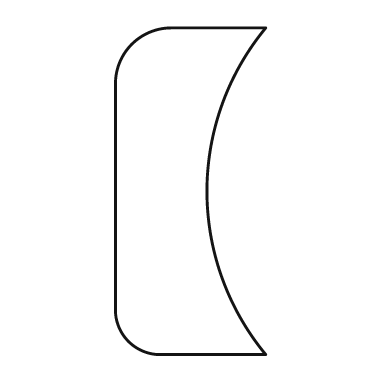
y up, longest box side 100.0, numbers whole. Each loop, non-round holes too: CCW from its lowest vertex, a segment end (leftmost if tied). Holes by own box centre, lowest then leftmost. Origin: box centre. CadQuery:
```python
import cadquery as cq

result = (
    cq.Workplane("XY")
    .moveTo(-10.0, -50.0)
    .lineTo(23.0, -50.0)
    .threePointArc((5.0, 0.0), (23.0, 50.0))
    .lineTo(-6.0, 50.0)
    .threePointArc((-18.0, 45.0), (-23.0, 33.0))
    .lineTo(-23.0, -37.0)
    .threePointArc((-19.0, -46.0), (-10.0, -50.0))
    .close()
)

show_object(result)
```